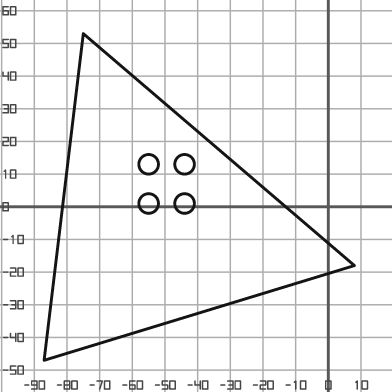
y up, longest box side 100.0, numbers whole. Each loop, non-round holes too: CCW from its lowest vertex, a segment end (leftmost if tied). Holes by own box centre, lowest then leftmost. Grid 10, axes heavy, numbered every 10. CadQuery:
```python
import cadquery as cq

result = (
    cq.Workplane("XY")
    .moveTo(-87.0, -47.0)
    .lineTo(8.0, -18.0)
    .lineTo(-75.0, 53.0)
    .close()
    .moveTo(-55.0, 1.0)
    .circle(3.0)
    .moveTo(-44.0, 1.0)
    .circle(3.0)
    .moveTo(-55.0, 13.0)
    .circle(3.0)
    .moveTo(-44.0, 13.0)
    .circle(3.0)
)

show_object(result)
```